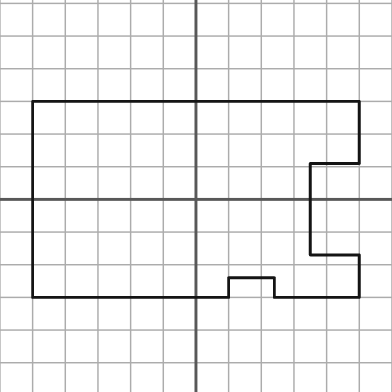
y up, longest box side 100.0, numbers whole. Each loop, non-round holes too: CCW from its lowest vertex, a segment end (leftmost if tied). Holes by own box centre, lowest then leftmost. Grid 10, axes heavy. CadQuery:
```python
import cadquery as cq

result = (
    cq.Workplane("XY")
    .moveTo(-50.0, -30.0)
    .lineTo(10.0, -30.0)
    .lineTo(10.0, -24.0)
    .lineTo(24.0, -24.0)
    .lineTo(24.0, -30.0)
    .lineTo(50.0, -30.0)
    .lineTo(50.0, -17.0)
    .lineTo(35.0, -17.0)
    .lineTo(35.0, 11.0)
    .lineTo(50.0, 11.0)
    .lineTo(50.0, 30.0)
    .lineTo(-50.0, 30.0)
    .close()
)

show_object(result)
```